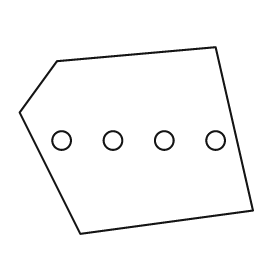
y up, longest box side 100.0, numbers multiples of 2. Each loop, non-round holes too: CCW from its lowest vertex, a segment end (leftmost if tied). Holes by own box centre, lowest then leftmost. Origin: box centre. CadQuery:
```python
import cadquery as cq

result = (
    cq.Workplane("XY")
    .moveTo(-24.0, -40.0)
    .lineTo(50.0, -30.0)
    .lineTo(34.0, 40.0)
    .lineTo(-34.0, 34.0)
    .lineTo(-50.0, 12.0)
    .close()
    .moveTo(-32.0, 0.0)
    .circle(4.0)
    .moveTo(-10.0, 0.0)
    .circle(4.0)
    .moveTo(12.0, 0.0)
    .circle(4.0)
    .moveTo(34.0, 0.0)
    .circle(4.0)
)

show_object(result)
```